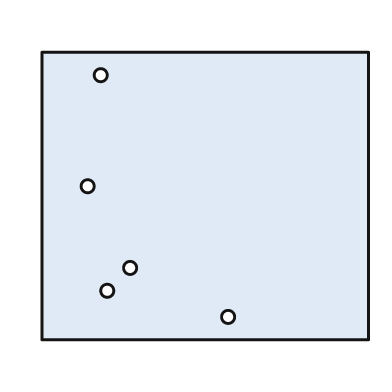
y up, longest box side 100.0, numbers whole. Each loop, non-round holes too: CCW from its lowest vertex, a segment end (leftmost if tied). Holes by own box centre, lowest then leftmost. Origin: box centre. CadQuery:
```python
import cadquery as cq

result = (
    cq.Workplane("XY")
    .moveTo(-50.0, -44.0)
    .lineTo(50.0, -44.0)
    .lineTo(50.0, 44.0)
    .lineTo(-50.0, 44.0)
    .close()
    .moveTo(7.0, -37.0)
    .circle(2.0)
    .moveTo(-30.0, -29.0)
    .circle(2.0)
    .moveTo(-23.0, -22.0)
    .circle(2.0)
    .moveTo(-36.0, 3.0)
    .circle(2.0)
    .moveTo(-32.0, 37.0)
    .circle(2.0)
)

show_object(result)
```